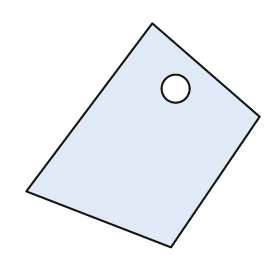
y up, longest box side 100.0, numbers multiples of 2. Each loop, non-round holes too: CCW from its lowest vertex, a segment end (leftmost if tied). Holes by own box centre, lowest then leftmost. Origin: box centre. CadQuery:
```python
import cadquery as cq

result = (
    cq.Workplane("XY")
    .moveTo(12.0, -48.0)
    .lineTo(50.0, 8.0)
    .lineTo(4.0, 48.0)
    .lineTo(-50.0, -24.0)
    .close()
    .moveTo(14.0, 20.0)
    .circle(6.0)
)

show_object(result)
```